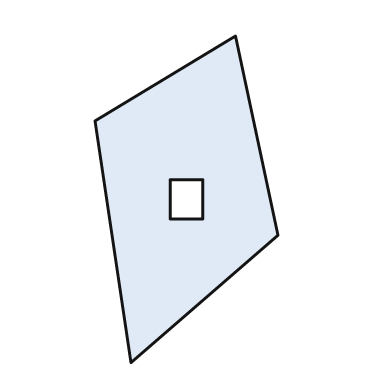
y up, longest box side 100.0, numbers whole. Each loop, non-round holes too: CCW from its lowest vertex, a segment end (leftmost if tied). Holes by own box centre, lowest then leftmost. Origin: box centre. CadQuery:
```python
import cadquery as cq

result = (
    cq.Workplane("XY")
    .moveTo(-17.0, -50.0)
    .lineTo(28.0, -11.0)
    .lineTo(15.0, 50.0)
    .lineTo(-28.0, 24.0)
    .close()
    .moveTo(-5.0, -6.0)
    .lineTo(5.0, -6.0)
    .lineTo(5.0, 6.0)
    .lineTo(-5.0, 6.0)
    .close()
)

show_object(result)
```